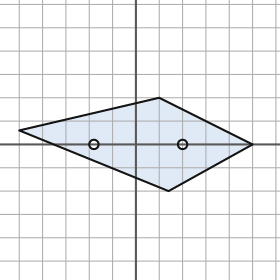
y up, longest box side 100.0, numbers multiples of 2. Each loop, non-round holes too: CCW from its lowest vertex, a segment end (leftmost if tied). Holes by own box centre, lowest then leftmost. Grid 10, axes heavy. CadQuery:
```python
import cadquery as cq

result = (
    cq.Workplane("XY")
    .moveTo(14.0, -20.0)
    .lineTo(50.0, 0.0)
    .lineTo(10.0, 20.0)
    .lineTo(-50.0, 6.0)
    .close()
    .moveTo(-18.0, 0.0)
    .circle(2.0)
    .moveTo(20.0, 0.0)
    .circle(2.0)
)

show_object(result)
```